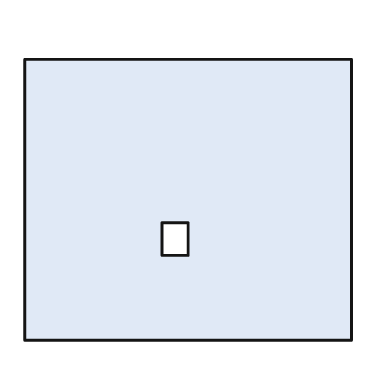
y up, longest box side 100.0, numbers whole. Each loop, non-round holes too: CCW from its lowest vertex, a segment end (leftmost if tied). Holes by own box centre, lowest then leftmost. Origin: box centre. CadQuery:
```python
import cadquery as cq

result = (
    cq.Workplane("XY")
    .moveTo(-50.0, -43.0)
    .lineTo(50.0, -43.0)
    .lineTo(50.0, 43.0)
    .lineTo(-50.0, 43.0)
    .close()
    .moveTo(-8.0, -17.0)
    .lineTo(0.0, -17.0)
    .lineTo(0.0, -7.0)
    .lineTo(-8.0, -7.0)
    .close()
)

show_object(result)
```